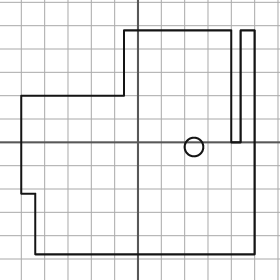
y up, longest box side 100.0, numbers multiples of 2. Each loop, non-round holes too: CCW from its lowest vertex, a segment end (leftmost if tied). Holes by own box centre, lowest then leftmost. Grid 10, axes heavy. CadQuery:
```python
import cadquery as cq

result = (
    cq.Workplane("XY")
    .moveTo(-44.0, -48.0)
    .lineTo(50.0, -48.0)
    .lineTo(50.0, 48.0)
    .lineTo(44.0, 48.0)
    .lineTo(44.0, 0.0)
    .lineTo(40.0, 0.0)
    .lineTo(40.0, 48.0)
    .lineTo(-6.0, 48.0)
    .lineTo(-6.0, 20.0)
    .lineTo(-50.0, 20.0)
    .lineTo(-50.0, -22.0)
    .lineTo(-44.0, -22.0)
    .close()
    .moveTo(24.0, -2.0)
    .circle(4.0)
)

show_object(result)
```